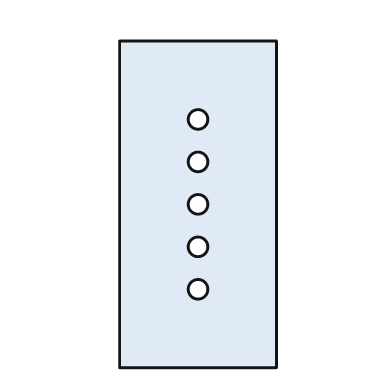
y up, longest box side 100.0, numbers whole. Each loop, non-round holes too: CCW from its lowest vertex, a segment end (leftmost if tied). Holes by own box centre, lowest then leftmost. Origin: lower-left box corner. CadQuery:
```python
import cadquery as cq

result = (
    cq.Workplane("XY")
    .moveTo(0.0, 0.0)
    .lineTo(48.0, 0.0)
    .lineTo(48.0, 100.0)
    .lineTo(0.0, 100.0)
    .close()
    .moveTo(24.0, 24.0)
    .circle(3.0)
    .moveTo(24.0, 37.0)
    .circle(3.0)
    .moveTo(24.0, 50.0)
    .circle(3.0)
    .moveTo(24.0, 63.0)
    .circle(3.0)
    .moveTo(24.0, 76.0)
    .circle(3.0)
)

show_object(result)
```